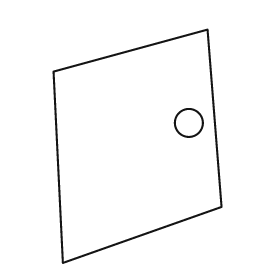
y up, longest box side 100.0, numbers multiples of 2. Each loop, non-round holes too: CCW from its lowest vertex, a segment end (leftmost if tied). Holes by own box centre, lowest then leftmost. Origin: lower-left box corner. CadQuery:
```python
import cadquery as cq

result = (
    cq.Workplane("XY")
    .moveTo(4.0, 0.0)
    .lineTo(72.0, 24.0)
    .lineTo(66.0, 100.0)
    .lineTo(0.0, 82.0)
    .close()
    .moveTo(58.0, 60.0)
    .circle(6.0)
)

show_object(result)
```